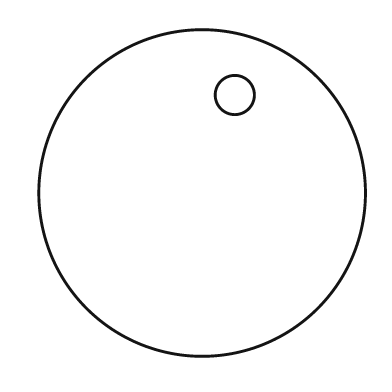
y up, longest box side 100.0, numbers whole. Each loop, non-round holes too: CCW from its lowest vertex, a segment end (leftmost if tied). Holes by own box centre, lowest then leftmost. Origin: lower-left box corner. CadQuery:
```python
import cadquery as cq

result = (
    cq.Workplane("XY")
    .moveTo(50.0, 50.0)
    .circle(50.0)
    .moveTo(60.0, 80.0)
    .circle(6.0)
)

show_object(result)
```